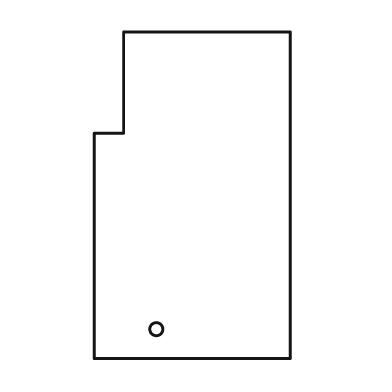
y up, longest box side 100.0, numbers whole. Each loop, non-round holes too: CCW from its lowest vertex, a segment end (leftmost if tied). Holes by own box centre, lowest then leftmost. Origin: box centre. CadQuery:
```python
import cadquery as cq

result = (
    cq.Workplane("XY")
    .moveTo(-30.0, -50.0)
    .lineTo(30.0, -50.0)
    .lineTo(30.0, 50.0)
    .lineTo(-21.0, 50.0)
    .lineTo(-21.0, 19.0)
    .lineTo(-30.0, 19.0)
    .close()
    .moveTo(-11.0, -41.0)
    .circle(2.0)
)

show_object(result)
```